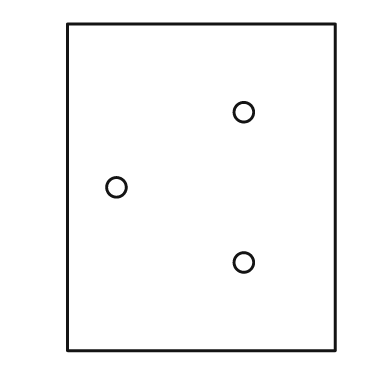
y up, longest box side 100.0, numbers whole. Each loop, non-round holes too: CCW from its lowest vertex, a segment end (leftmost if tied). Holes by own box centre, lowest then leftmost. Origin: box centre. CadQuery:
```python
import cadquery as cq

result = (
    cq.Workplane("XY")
    .moveTo(-41.0, -50.0)
    .lineTo(41.0, -50.0)
    .lineTo(41.0, 50.0)
    .lineTo(-41.0, 50.0)
    .close()
    .moveTo(13.0, -23.0)
    .circle(3.0)
    .moveTo(-26.0, 0.0)
    .circle(3.0)
    .moveTo(13.0, 23.0)
    .circle(3.0)
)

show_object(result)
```